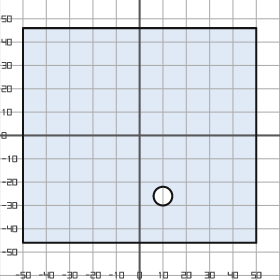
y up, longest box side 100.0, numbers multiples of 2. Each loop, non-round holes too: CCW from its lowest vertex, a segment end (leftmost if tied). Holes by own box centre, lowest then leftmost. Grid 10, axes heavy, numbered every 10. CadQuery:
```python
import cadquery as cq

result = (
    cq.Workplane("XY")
    .moveTo(-50.0, -46.0)
    .lineTo(50.0, -46.0)
    .lineTo(50.0, 46.0)
    .lineTo(-50.0, 46.0)
    .close()
    .moveTo(10.0, -26.0)
    .circle(4.0)
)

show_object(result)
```